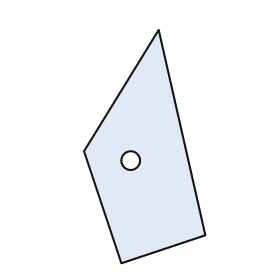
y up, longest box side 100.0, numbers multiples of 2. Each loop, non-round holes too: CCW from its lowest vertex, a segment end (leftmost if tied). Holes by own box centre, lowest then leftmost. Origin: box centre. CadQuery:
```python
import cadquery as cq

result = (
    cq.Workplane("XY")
    .moveTo(-10.0, -50.0)
    .lineTo(26.0, -38.0)
    .lineTo(6.0, 50.0)
    .lineTo(-26.0, -2.0)
    .close()
    .moveTo(-6.0, -6.0)
    .circle(4.0)
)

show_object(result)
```